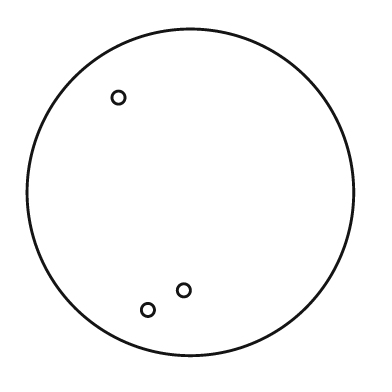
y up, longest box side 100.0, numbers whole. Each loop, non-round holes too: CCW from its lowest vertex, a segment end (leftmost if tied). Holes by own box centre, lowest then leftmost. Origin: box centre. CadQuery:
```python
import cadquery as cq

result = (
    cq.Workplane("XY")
    .moveTo(0.0, 0.0)
    .circle(50.0)
    .moveTo(-13.0, -36.0)
    .circle(2.0)
    .moveTo(-2.0, -30.0)
    .circle(2.0)
    .moveTo(-22.0, 29.0)
    .circle(2.0)
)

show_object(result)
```